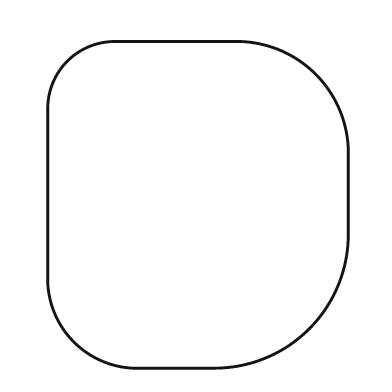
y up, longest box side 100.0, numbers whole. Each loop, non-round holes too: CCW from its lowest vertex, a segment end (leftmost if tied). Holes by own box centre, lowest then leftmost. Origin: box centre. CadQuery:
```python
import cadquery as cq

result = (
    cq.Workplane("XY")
    .moveTo(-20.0, -50.0)
    .lineTo(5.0, -50.0)
    .threePointArc((34.0, -38.0), (46.0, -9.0))
    .lineTo(46.0, 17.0)
    .threePointArc((36.0, 40.0), (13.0, 50.0))
    .lineTo(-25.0, 50.0)
    .threePointArc((-40.0, 44.0), (-46.0, 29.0))
    .lineTo(-46.0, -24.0)
    .threePointArc((-38.0, -42.0), (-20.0, -50.0))
    .close()
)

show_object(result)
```